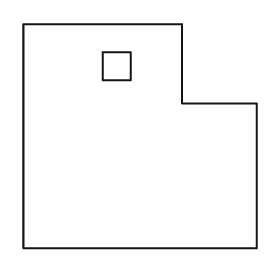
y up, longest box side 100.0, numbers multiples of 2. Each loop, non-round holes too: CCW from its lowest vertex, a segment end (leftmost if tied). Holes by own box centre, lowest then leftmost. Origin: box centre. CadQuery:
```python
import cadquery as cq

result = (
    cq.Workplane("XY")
    .moveTo(-50.0, -48.0)
    .lineTo(50.0, -48.0)
    .lineTo(50.0, 14.0)
    .lineTo(18.0, 14.0)
    .lineTo(18.0, 48.0)
    .lineTo(-50.0, 48.0)
    .close()
    .moveTo(-16.0, 24.0)
    .lineTo(-4.0, 24.0)
    .lineTo(-4.0, 36.0)
    .lineTo(-16.0, 36.0)
    .close()
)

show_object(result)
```